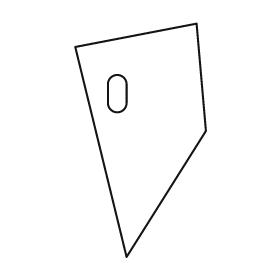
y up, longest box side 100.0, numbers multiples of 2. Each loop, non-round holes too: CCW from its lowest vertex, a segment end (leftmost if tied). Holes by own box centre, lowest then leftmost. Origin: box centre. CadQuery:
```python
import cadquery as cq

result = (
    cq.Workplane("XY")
    .moveTo(-6.0, -50.0)
    .lineTo(28.0, 4.0)
    .lineTo(24.0, 50.0)
    .lineTo(-28.0, 40.0)
    .close()
    .moveTo(-14.0, 16.0)
    .threePointArc((-10.0, 12.0), (-6.0, 16.0))
    .lineTo(-6.0, 24.0)
    .threePointArc((-10.0, 28.0), (-14.0, 24.0))
    .close()
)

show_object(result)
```